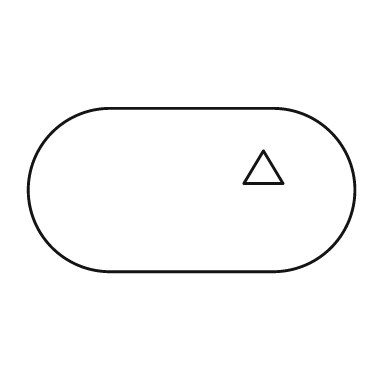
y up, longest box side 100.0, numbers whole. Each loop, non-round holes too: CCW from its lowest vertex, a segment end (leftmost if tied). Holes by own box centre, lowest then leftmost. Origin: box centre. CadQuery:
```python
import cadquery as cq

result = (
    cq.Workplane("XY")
    .moveTo(-25.0, -25.0)
    .lineTo(25.0, -25.0)
    .threePointArc((50.0, 0.0), (25.0, 25.0))
    .lineTo(-25.0, 25.0)
    .threePointArc((-50.0, 0.0), (-25.0, -25.0))
    .close()
    .moveTo(16.0, 2.0)
    .lineTo(28.0, 2.0)
    .lineTo(22.0, 12.0)
    .close()
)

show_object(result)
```